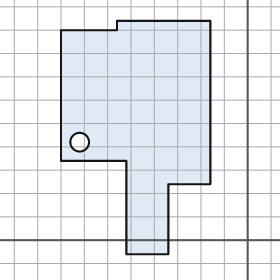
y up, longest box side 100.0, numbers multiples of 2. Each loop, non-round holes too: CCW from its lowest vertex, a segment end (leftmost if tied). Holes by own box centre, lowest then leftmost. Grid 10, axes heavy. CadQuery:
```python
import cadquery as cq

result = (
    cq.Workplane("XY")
    .moveTo(-52.0, -6.0)
    .lineTo(-34.0, -6.0)
    .lineTo(-34.0, 24.0)
    .lineTo(-16.0, 24.0)
    .lineTo(-16.0, 94.0)
    .lineTo(-56.0, 94.0)
    .lineTo(-56.0, 90.0)
    .lineTo(-80.0, 90.0)
    .lineTo(-80.0, 34.0)
    .lineTo(-52.0, 34.0)
    .close()
    .moveTo(-72.0, 42.0)
    .circle(4.0)
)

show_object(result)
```